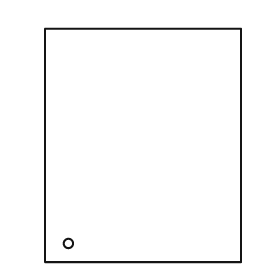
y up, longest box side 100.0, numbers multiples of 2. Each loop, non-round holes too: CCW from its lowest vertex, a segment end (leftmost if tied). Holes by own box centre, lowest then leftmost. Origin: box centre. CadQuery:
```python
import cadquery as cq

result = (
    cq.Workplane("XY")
    .moveTo(-42.0, -50.0)
    .lineTo(42.0, -50.0)
    .lineTo(42.0, 50.0)
    .lineTo(-42.0, 50.0)
    .close()
    .moveTo(-32.0, -42.0)
    .circle(2.0)
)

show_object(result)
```